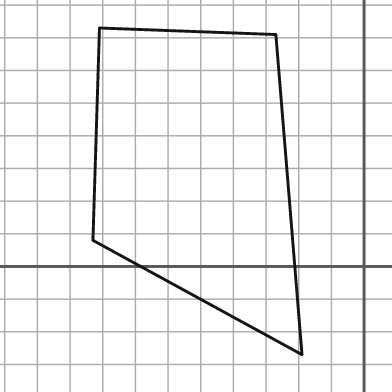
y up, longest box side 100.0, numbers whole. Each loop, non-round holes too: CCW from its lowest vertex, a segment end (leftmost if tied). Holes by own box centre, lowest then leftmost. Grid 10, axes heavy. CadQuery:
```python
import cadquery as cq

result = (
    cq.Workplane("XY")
    .moveTo(-19.0, -27.0)
    .lineTo(-27.0, 71.0)
    .lineTo(-81.0, 73.0)
    .lineTo(-83.0, 8.0)
    .close()
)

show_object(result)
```